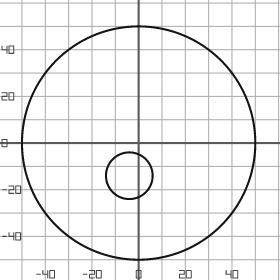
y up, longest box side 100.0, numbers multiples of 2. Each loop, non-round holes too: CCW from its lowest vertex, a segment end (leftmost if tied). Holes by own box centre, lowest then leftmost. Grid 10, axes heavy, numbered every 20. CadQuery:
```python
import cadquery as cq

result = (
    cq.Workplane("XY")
    .moveTo(0.0, 0.0)
    .circle(50.0)
    .moveTo(-4.0, -14.0)
    .circle(10.0)
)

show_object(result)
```